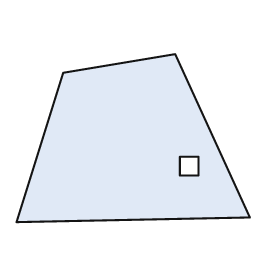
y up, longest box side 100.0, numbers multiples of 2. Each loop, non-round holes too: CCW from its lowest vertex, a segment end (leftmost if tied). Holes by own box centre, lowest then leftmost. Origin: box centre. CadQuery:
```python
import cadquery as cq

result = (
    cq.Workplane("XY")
    .moveTo(-50.0, -36.0)
    .lineTo(50.0, -34.0)
    .lineTo(18.0, 36.0)
    .lineTo(-30.0, 28.0)
    .close()
    .moveTo(20.0, -16.0)
    .lineTo(28.0, -16.0)
    .lineTo(28.0, -8.0)
    .lineTo(20.0, -8.0)
    .close()
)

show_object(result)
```